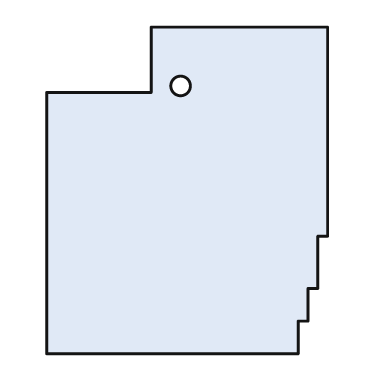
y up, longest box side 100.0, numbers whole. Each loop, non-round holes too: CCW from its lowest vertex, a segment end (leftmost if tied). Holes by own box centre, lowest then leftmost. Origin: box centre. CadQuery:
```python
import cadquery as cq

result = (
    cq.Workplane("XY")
    .moveTo(-43.0, -50.0)
    .lineTo(34.0, -50.0)
    .lineTo(34.0, -40.0)
    .lineTo(37.0, -40.0)
    .lineTo(37.0, -30.0)
    .lineTo(40.0, -30.0)
    .lineTo(40.0, -14.0)
    .lineTo(43.0, -14.0)
    .lineTo(43.0, 50.0)
    .lineTo(-11.0, 50.0)
    .lineTo(-11.0, 30.0)
    .lineTo(-43.0, 30.0)
    .close()
    .moveTo(-2.0, 32.0)
    .circle(3.0)
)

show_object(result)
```